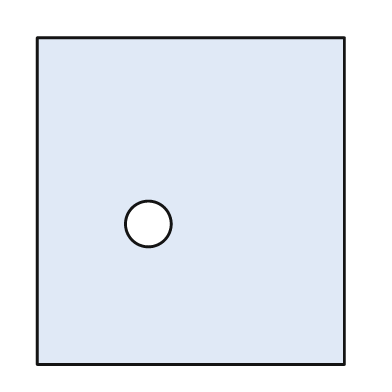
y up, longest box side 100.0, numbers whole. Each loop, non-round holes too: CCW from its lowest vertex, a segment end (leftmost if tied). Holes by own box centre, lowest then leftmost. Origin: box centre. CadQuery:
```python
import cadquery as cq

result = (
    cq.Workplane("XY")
    .moveTo(-47.0, -50.0)
    .lineTo(47.0, -50.0)
    .lineTo(47.0, 50.0)
    .lineTo(-47.0, 50.0)
    .close()
    .moveTo(-13.0, -7.0)
    .circle(7.0)
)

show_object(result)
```